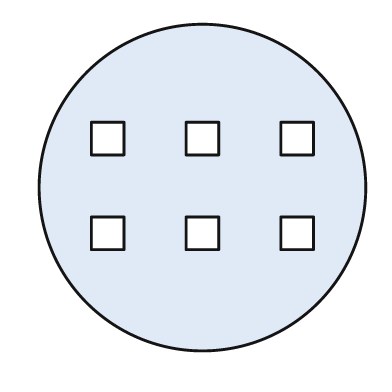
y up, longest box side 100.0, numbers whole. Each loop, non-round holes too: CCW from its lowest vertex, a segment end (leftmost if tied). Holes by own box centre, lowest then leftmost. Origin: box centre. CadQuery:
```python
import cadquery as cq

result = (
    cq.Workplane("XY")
    .moveTo(0.0, 0.0)
    .circle(50.0)
    .moveTo(-34.0, -19.0)
    .lineTo(-24.0, -19.0)
    .lineTo(-24.0, -9.0)
    .lineTo(-34.0, -9.0)
    .close()
    .moveTo(-5.0, -19.0)
    .lineTo(5.0, -19.0)
    .lineTo(5.0, -9.0)
    .lineTo(-5.0, -9.0)
    .close()
    .moveTo(24.0, -19.0)
    .lineTo(34.0, -19.0)
    .lineTo(34.0, -9.0)
    .lineTo(24.0, -9.0)
    .close()
    .moveTo(-34.0, 10.0)
    .lineTo(-24.0, 10.0)
    .lineTo(-24.0, 20.0)
    .lineTo(-34.0, 20.0)
    .close()
    .moveTo(-5.0, 10.0)
    .lineTo(5.0, 10.0)
    .lineTo(5.0, 20.0)
    .lineTo(-5.0, 20.0)
    .close()
    .moveTo(24.0, 10.0)
    .lineTo(34.0, 10.0)
    .lineTo(34.0, 20.0)
    .lineTo(24.0, 20.0)
    .close()
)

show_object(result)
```